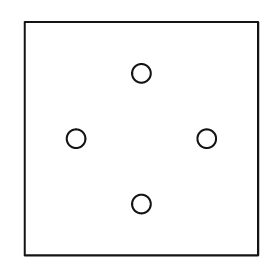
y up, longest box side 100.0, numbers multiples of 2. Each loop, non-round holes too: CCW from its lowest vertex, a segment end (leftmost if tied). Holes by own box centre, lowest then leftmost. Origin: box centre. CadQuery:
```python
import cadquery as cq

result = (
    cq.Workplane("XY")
    .moveTo(-50.0, -50.0)
    .lineTo(50.0, -50.0)
    .lineTo(50.0, 50.0)
    .lineTo(-50.0, 50.0)
    .close()
    .moveTo(0.0, -28.0)
    .circle(4.0)
    .moveTo(-28.0, 0.0)
    .circle(4.0)
    .moveTo(28.0, 0.0)
    .circle(4.0)
    .moveTo(0.0, 28.0)
    .circle(4.0)
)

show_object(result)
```